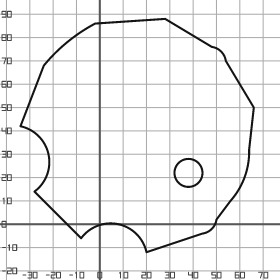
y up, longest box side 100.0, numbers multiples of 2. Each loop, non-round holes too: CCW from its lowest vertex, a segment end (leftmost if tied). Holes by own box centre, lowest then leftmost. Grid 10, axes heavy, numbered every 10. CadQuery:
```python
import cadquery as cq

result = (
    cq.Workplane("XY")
    .moveTo(20.0, -12.0)
    .lineTo(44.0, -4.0)
    .threePointArc((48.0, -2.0), (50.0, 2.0))
    .lineTo(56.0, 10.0)
    .threePointArc((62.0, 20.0), (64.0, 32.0))
    .lineTo(66.0, 50.0)
    .lineTo(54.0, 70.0)
    .threePointArc((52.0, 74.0), (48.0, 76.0))
    .lineTo(28.0, 88.0)
    .lineTo(-2.0, 86.0)
    .threePointArc((-14.0, 78.0), (-24.0, 68.0))
    .lineTo(-34.0, 42.0)
    .threePointArc((-22.0, 30.0), (-28.0, 14.0))
    .lineTo(-8.0, -6.0)
    .threePointArc((8.0, 0.0), (20.0, -12.0))
    .close()
    .moveTo(38.0, 22.0)
    .circle(6.0)
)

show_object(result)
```